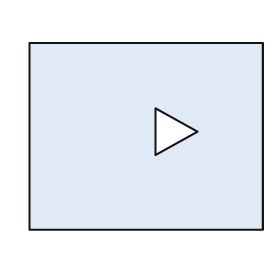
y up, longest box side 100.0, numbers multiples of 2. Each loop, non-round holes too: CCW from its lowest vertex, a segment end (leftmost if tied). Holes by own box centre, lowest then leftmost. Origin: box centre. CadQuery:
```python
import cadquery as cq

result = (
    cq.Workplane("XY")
    .moveTo(-50.0, -40.0)
    .lineTo(50.0, -40.0)
    .lineTo(50.0, 40.0)
    .lineTo(-50.0, 40.0)
    .close()
    .moveTo(4.0, -8.0)
    .lineTo(22.0, 2.0)
    .lineTo(4.0, 12.0)
    .close()
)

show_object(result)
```